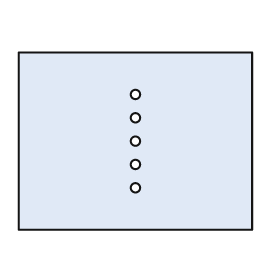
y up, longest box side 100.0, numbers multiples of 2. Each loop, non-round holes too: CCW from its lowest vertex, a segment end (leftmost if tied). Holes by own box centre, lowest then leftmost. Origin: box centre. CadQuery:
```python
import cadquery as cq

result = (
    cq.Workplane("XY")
    .moveTo(-50.0, -38.0)
    .lineTo(50.0, -38.0)
    .lineTo(50.0, 38.0)
    .lineTo(-50.0, 38.0)
    .close()
    .moveTo(0.0, -20.0)
    .circle(2.0)
    .moveTo(0.0, -10.0)
    .circle(2.0)
    .moveTo(0.0, 0.0)
    .circle(2.0)
    .moveTo(0.0, 10.0)
    .circle(2.0)
    .moveTo(0.0, 20.0)
    .circle(2.0)
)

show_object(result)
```